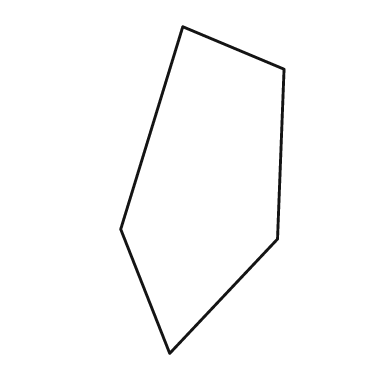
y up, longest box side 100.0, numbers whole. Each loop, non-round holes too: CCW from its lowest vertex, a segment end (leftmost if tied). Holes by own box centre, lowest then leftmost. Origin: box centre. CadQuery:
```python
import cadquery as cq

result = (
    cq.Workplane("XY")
    .moveTo(-10.0, -50.0)
    .lineTo(23.0, -15.0)
    .lineTo(25.0, 37.0)
    .lineTo(-6.0, 50.0)
    .lineTo(-25.0, -12.0)
    .close()
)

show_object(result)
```